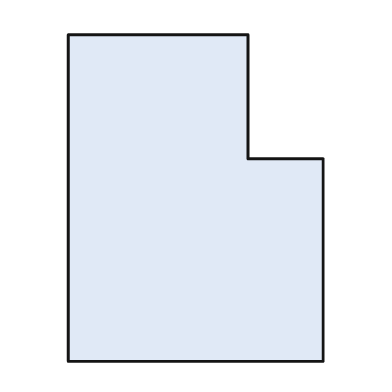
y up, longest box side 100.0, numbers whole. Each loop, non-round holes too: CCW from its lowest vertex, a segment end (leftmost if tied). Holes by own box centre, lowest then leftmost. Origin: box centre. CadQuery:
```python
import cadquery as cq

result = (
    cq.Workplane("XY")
    .moveTo(-39.0, -50.0)
    .lineTo(39.0, -50.0)
    .lineTo(39.0, 12.0)
    .lineTo(16.0, 12.0)
    .lineTo(16.0, 50.0)
    .lineTo(-39.0, 50.0)
    .close()
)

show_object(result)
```